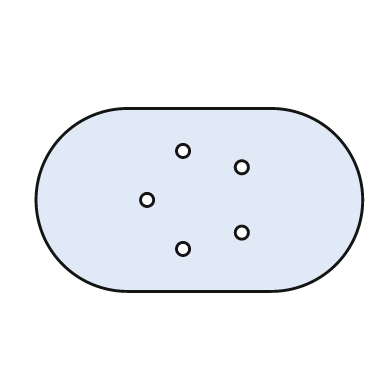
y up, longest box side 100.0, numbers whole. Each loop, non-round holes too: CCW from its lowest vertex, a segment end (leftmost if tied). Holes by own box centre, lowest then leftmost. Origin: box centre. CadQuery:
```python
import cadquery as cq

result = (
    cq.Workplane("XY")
    .moveTo(-22.0, -28.0)
    .lineTo(22.0, -28.0)
    .threePointArc((50.0, 0.0), (22.0, 28.0))
    .lineTo(-22.0, 28.0)
    .threePointArc((-50.0, 0.0), (-22.0, -28.0))
    .close()
    .moveTo(-5.0, -15.0)
    .circle(2.0)
    .moveTo(13.0, -10.0)
    .circle(2.0)
    .moveTo(-16.0, 0.0)
    .circle(2.0)
    .moveTo(13.0, 10.0)
    .circle(2.0)
    .moveTo(-5.0, 15.0)
    .circle(2.0)
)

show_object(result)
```